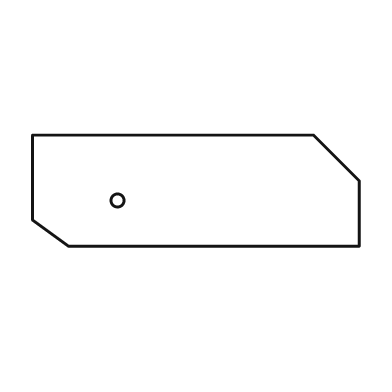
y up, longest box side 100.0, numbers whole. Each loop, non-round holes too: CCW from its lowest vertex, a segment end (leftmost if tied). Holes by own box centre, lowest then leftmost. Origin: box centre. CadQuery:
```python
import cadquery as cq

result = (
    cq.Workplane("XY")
    .moveTo(-39.0, -17.0)
    .lineTo(50.0, -17.0)
    .lineTo(50.0, 3.0)
    .lineTo(36.0, 17.0)
    .lineTo(-50.0, 17.0)
    .lineTo(-50.0, -9.0)
    .close()
    .moveTo(-24.0, -3.0)
    .circle(2.0)
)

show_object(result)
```